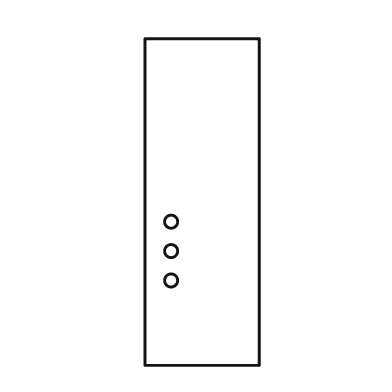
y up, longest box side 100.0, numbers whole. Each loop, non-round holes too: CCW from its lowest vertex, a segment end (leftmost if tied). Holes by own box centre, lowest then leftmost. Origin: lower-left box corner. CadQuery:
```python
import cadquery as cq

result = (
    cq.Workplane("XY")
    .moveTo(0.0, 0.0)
    .lineTo(35.0, 0.0)
    .lineTo(35.0, 100.0)
    .lineTo(0.0, 100.0)
    .close()
    .moveTo(8.0, 26.0)
    .circle(2.0)
    .moveTo(8.0, 35.0)
    .circle(2.0)
    .moveTo(8.0, 44.0)
    .circle(2.0)
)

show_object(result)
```